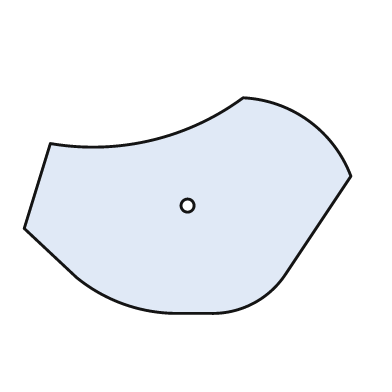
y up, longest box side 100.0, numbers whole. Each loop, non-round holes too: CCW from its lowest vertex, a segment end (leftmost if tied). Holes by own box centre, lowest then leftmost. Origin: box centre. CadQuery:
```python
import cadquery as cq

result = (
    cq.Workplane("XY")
    .moveTo(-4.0, -33.0)
    .lineTo(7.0, -33.0)
    .threePointArc((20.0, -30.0), (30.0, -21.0))
    .lineTo(50.0, 9.0)
    .threePointArc((37.0, 26.0), (17.0, 33.0))
    .threePointArc((-11.0, 20.0), (-42.0, 19.0))
    .lineTo(-50.0, -7.0)
    .lineTo(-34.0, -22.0)
    .threePointArc((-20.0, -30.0), (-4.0, -33.0))
    .close()
    .moveTo(0.0, 0.0)
    .circle(2.0)
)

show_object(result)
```